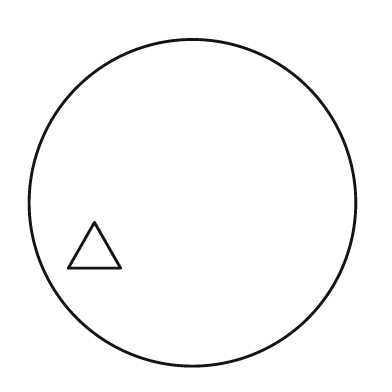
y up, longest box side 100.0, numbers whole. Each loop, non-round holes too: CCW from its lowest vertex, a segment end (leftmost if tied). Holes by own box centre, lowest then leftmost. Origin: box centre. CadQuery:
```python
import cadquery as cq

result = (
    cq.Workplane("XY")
    .moveTo(0.0, 0.0)
    .circle(50.0)
    .moveTo(-38.0, -20.0)
    .lineTo(-22.0, -20.0)
    .lineTo(-30.0, -6.0)
    .close()
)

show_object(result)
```